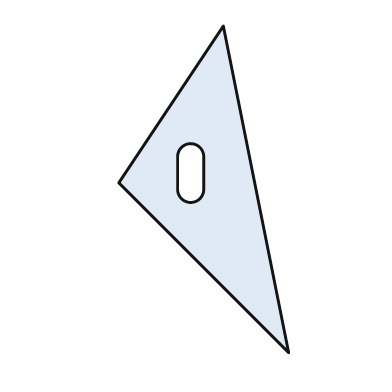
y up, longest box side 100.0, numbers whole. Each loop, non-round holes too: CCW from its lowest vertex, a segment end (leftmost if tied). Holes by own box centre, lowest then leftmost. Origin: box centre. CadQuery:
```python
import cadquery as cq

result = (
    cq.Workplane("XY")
    .moveTo(26.0, -50.0)
    .lineTo(6.0, 50.0)
    .lineTo(-26.0, 2.0)
    .close()
    .moveTo(-8.0, 0.0)
    .threePointArc((-4.0, -4.0), (0.0, 0.0))
    .lineTo(0.0, 10.0)
    .threePointArc((-4.0, 14.0), (-8.0, 10.0))
    .close()
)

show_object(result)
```